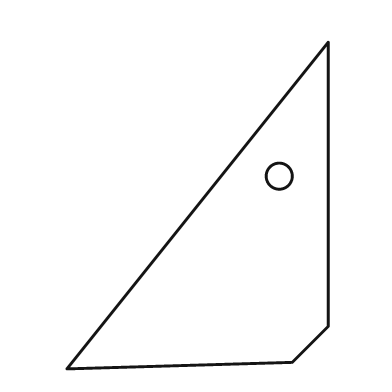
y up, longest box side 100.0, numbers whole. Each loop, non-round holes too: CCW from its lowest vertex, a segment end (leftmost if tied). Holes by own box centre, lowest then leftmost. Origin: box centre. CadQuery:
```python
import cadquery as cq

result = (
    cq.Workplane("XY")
    .moveTo(-40.0, -50.0)
    .lineTo(29.0, -48.0)
    .lineTo(40.0, -37.0)
    .lineTo(40.0, 50.0)
    .close()
    .moveTo(25.0, 9.0)
    .circle(4.0)
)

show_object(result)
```